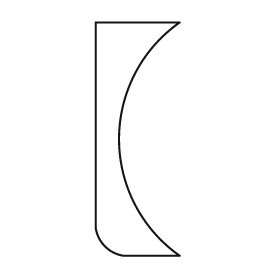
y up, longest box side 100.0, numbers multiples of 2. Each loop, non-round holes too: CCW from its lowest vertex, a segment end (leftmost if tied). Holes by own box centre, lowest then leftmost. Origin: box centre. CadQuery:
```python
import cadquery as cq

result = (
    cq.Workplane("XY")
    .moveTo(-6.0, -50.0)
    .lineTo(18.0, -50.0)
    .threePointArc((-8.0, 0.0), (18.0, 50.0))
    .lineTo(-18.0, 50.0)
    .lineTo(-18.0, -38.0)
    .threePointArc((-14.0, -46.0), (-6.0, -50.0))
    .close()
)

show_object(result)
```